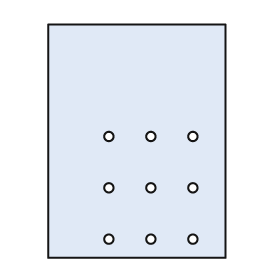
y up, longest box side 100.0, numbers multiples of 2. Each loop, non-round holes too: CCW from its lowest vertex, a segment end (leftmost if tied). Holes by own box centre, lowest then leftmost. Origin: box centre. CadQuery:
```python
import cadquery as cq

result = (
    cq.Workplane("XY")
    .moveTo(-38.0, -50.0)
    .lineTo(38.0, -50.0)
    .lineTo(38.0, 50.0)
    .lineTo(-38.0, 50.0)
    .close()
    .moveTo(-12.0, -42.0)
    .circle(2.0)
    .moveTo(6.0, -42.0)
    .circle(2.0)
    .moveTo(24.0, -42.0)
    .circle(2.0)
    .moveTo(-12.0, -20.0)
    .circle(2.0)
    .moveTo(6.0, -20.0)
    .circle(2.0)
    .moveTo(24.0, -20.0)
    .circle(2.0)
    .moveTo(-12.0, 2.0)
    .circle(2.0)
    .moveTo(6.0, 2.0)
    .circle(2.0)
    .moveTo(24.0, 2.0)
    .circle(2.0)
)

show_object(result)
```